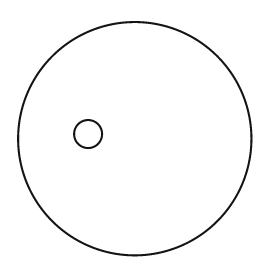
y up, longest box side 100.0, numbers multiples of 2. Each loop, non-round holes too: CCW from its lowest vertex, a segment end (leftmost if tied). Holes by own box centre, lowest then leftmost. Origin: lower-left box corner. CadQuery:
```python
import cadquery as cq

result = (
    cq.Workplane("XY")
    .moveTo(50.0, 50.0)
    .circle(50.0)
    .moveTo(30.0, 52.0)
    .circle(6.0)
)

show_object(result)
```